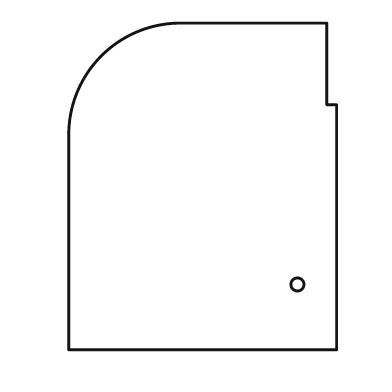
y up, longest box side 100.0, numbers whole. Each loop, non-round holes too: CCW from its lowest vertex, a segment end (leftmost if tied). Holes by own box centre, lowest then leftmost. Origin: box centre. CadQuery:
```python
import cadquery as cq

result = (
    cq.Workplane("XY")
    .moveTo(-41.0, -50.0)
    .lineTo(41.0, -50.0)
    .lineTo(41.0, 25.0)
    .lineTo(38.0, 25.0)
    .lineTo(38.0, 50.0)
    .lineTo(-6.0, 50.0)
    .threePointArc((-31.0, 40.0), (-41.0, 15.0))
    .close()
    .moveTo(29.0, -30.0)
    .circle(2.0)
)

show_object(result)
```